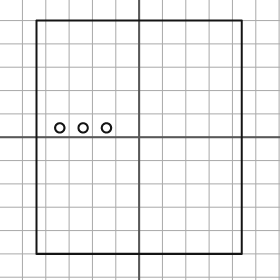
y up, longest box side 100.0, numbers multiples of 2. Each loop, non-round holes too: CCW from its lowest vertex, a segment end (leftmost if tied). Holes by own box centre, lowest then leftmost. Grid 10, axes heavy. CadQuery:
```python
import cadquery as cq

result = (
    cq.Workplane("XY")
    .moveTo(-44.0, -50.0)
    .lineTo(44.0, -50.0)
    .lineTo(44.0, 50.0)
    .lineTo(-44.0, 50.0)
    .close()
    .moveTo(-34.0, 4.0)
    .circle(2.0)
    .moveTo(-24.0, 4.0)
    .circle(2.0)
    .moveTo(-14.0, 4.0)
    .circle(2.0)
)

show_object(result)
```